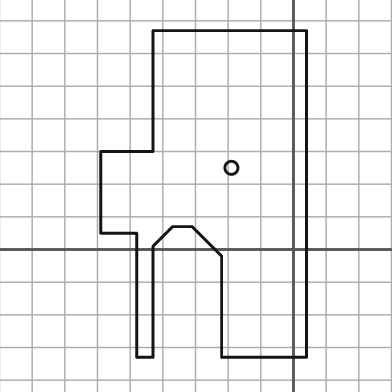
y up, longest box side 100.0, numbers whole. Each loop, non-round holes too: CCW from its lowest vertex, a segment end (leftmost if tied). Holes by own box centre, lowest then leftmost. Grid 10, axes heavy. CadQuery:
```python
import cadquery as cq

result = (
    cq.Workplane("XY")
    .moveTo(-48.0, -33.0)
    .lineTo(-43.0, -33.0)
    .lineTo(-43.0, 1.0)
    .lineTo(-37.0, 7.0)
    .lineTo(-31.0, 7.0)
    .lineTo(-22.0, -2.0)
    .lineTo(-22.0, -33.0)
    .lineTo(4.0, -33.0)
    .lineTo(4.0, 67.0)
    .lineTo(-43.0, 67.0)
    .lineTo(-43.0, 30.0)
    .lineTo(-59.0, 30.0)
    .lineTo(-59.0, 5.0)
    .lineTo(-48.0, 5.0)
    .close()
    .moveTo(-19.0, 25.0)
    .circle(2.0)
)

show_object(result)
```